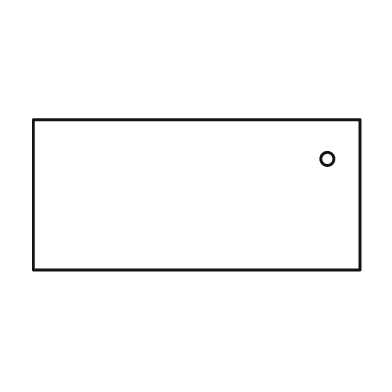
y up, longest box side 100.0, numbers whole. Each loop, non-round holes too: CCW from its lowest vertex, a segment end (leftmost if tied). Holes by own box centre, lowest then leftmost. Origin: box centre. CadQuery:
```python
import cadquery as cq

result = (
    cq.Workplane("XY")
    .moveTo(-50.0, -23.0)
    .lineTo(50.0, -23.0)
    .lineTo(50.0, 23.0)
    .lineTo(-50.0, 23.0)
    .close()
    .moveTo(40.0, 11.0)
    .circle(2.0)
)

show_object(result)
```